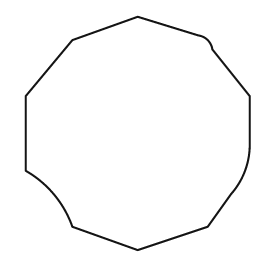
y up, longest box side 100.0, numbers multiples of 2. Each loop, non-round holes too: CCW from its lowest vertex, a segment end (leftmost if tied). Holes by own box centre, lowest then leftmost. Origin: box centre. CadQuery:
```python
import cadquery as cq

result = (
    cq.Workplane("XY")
    .moveTo(0.0, -50.0)
    .lineTo(30.0, -40.0)
    .lineTo(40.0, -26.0)
    .threePointArc((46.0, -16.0), (48.0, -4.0))
    .lineTo(48.0, 16.0)
    .lineTo(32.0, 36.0)
    .threePointArc((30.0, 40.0), (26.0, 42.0))
    .lineTo(0.0, 50.0)
    .lineTo(-28.0, 40.0)
    .lineTo(-48.0, 16.0)
    .lineTo(-48.0, -16.0)
    .threePointArc((-36.0, -26.0), (-28.0, -40.0))
    .close()
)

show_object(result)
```